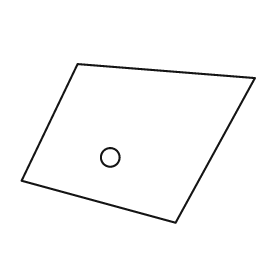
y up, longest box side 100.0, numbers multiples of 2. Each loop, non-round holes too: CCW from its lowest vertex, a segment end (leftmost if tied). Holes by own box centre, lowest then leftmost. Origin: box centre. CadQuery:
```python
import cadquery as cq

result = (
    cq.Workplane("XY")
    .moveTo(16.0, -34.0)
    .lineTo(50.0, 28.0)
    .lineTo(-26.0, 34.0)
    .lineTo(-50.0, -16.0)
    .close()
    .moveTo(-12.0, -6.0)
    .circle(4.0)
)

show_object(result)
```